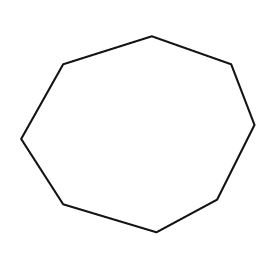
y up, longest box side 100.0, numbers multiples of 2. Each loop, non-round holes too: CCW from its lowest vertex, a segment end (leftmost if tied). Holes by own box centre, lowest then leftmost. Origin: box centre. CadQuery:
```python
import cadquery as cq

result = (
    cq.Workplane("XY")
    .moveTo(8.0, -42.0)
    .lineTo(34.0, -28.0)
    .lineTo(50.0, 4.0)
    .lineTo(40.0, 30.0)
    .lineTo(6.0, 42.0)
    .lineTo(-32.0, 30.0)
    .lineTo(-50.0, -2.0)
    .lineTo(-32.0, -30.0)
    .close()
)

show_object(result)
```